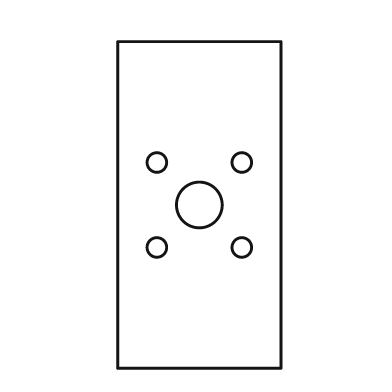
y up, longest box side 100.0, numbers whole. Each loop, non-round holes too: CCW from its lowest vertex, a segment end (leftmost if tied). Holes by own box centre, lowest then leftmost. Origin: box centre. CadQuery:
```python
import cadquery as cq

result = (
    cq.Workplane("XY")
    .moveTo(-25.0, -50.0)
    .lineTo(25.0, -50.0)
    .lineTo(25.0, 50.0)
    .lineTo(-25.0, 50.0)
    .close()
    .moveTo(-13.0, -13.0)
    .circle(3.0)
    .moveTo(13.0, -13.0)
    .circle(3.0)
    .moveTo(0.0, 0.0)
    .circle(7.0)
    .moveTo(-13.0, 13.0)
    .circle(3.0)
    .moveTo(13.0, 13.0)
    .circle(3.0)
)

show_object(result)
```